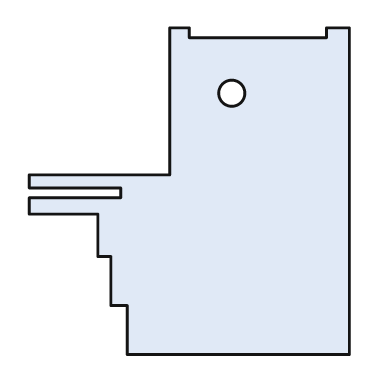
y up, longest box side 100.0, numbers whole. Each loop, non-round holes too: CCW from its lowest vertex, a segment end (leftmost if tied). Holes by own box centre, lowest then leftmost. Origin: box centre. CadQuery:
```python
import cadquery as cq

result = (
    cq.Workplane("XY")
    .moveTo(-19.0, -50.0)
    .lineTo(49.0, -50.0)
    .lineTo(49.0, 50.0)
    .lineTo(42.0, 50.0)
    .lineTo(42.0, 47.0)
    .lineTo(0.0, 47.0)
    .lineTo(0.0, 50.0)
    .lineTo(-6.0, 50.0)
    .lineTo(-6.0, 5.0)
    .lineTo(-49.0, 5.0)
    .lineTo(-49.0, 1.0)
    .lineTo(-21.0, 1.0)
    .lineTo(-21.0, -2.0)
    .lineTo(-49.0, -2.0)
    .lineTo(-49.0, -7.0)
    .lineTo(-28.0, -7.0)
    .lineTo(-28.0, -20.0)
    .lineTo(-24.0, -20.0)
    .lineTo(-24.0, -35.0)
    .lineTo(-19.0, -35.0)
    .close()
    .moveTo(13.0, 30.0)
    .circle(4.0)
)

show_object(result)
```